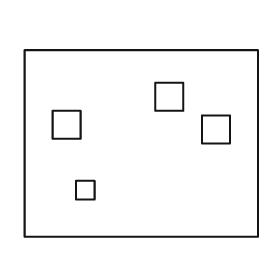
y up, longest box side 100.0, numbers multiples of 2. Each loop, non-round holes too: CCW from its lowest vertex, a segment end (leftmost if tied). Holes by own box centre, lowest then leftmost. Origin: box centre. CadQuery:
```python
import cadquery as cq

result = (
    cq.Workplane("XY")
    .moveTo(-50.0, -40.0)
    .lineTo(50.0, -40.0)
    .lineTo(50.0, 40.0)
    .lineTo(-50.0, 40.0)
    .close()
    .moveTo(-28.0, -24.0)
    .lineTo(-20.0, -24.0)
    .lineTo(-20.0, -16.0)
    .lineTo(-28.0, -16.0)
    .close()
    .moveTo(26.0, 0.0)
    .lineTo(38.0, 0.0)
    .lineTo(38.0, 12.0)
    .lineTo(26.0, 12.0)
    .close()
    .moveTo(-38.0, 2.0)
    .lineTo(-26.0, 2.0)
    .lineTo(-26.0, 14.0)
    .lineTo(-38.0, 14.0)
    .close()
    .moveTo(6.0, 14.0)
    .lineTo(18.0, 14.0)
    .lineTo(18.0, 26.0)
    .lineTo(6.0, 26.0)
    .close()
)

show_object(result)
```